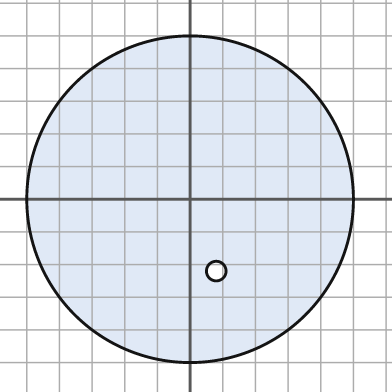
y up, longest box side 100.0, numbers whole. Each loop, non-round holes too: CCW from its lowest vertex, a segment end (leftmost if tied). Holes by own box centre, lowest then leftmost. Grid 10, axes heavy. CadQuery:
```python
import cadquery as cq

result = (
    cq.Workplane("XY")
    .moveTo(0.0, 0.0)
    .circle(50.0)
    .moveTo(8.0, -22.0)
    .circle(3.0)
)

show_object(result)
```